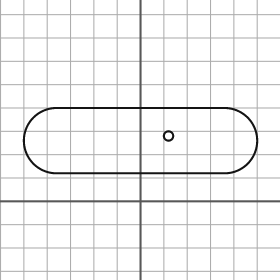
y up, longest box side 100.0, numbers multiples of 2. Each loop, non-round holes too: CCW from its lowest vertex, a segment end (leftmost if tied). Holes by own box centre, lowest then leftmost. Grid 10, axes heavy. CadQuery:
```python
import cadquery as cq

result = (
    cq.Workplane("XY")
    .moveTo(-36.0, 12.0)
    .lineTo(36.0, 12.0)
    .threePointArc((50.0, 26.0), (36.0, 40.0))
    .lineTo(-36.0, 40.0)
    .threePointArc((-50.0, 26.0), (-36.0, 12.0))
    .close()
    .moveTo(12.0, 28.0)
    .circle(2.0)
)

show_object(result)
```